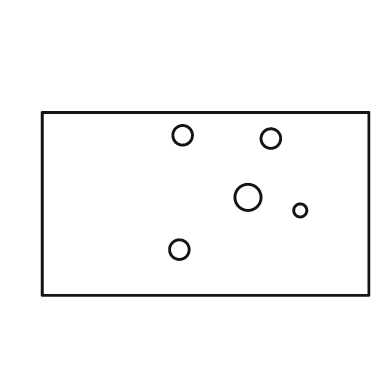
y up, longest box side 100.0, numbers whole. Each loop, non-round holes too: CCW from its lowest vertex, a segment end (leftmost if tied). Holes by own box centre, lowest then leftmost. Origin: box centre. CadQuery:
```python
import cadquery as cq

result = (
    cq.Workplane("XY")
    .moveTo(-50.0, -28.0)
    .lineTo(50.0, -28.0)
    .lineTo(50.0, 28.0)
    .lineTo(-50.0, 28.0)
    .close()
    .moveTo(-8.0, -14.0)
    .circle(3.0)
    .moveTo(29.0, -2.0)
    .circle(2.0)
    .moveTo(13.0, 2.0)
    .circle(4.0)
    .moveTo(20.0, 20.0)
    .circle(3.0)
    .moveTo(-7.0, 21.0)
    .circle(3.0)
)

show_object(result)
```